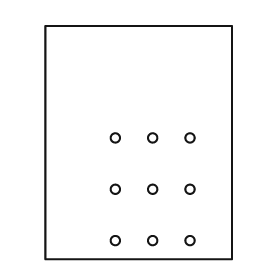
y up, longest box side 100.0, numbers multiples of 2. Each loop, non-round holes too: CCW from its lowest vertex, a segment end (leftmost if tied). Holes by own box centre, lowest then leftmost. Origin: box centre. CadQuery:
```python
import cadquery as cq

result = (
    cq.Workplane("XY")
    .moveTo(-40.0, -50.0)
    .lineTo(40.0, -50.0)
    .lineTo(40.0, 50.0)
    .lineTo(-40.0, 50.0)
    .close()
    .moveTo(-10.0, -42.0)
    .circle(2.0)
    .moveTo(6.0, -42.0)
    .circle(2.0)
    .moveTo(22.0, -42.0)
    .circle(2.0)
    .moveTo(-10.0, -20.0)
    .circle(2.0)
    .moveTo(6.0, -20.0)
    .circle(2.0)
    .moveTo(22.0, -20.0)
    .circle(2.0)
    .moveTo(-10.0, 2.0)
    .circle(2.0)
    .moveTo(6.0, 2.0)
    .circle(2.0)
    .moveTo(22.0, 2.0)
    .circle(2.0)
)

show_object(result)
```